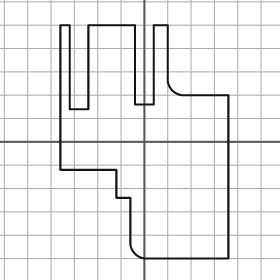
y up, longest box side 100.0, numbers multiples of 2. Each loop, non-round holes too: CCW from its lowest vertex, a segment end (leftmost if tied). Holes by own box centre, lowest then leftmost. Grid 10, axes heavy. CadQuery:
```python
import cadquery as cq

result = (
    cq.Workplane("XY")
    .moveTo(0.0, -50.0)
    .lineTo(36.0, -50.0)
    .lineTo(36.0, 20.0)
    .lineTo(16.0, 20.0)
    .threePointArc((12.0, 22.0), (10.0, 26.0))
    .lineTo(10.0, 50.0)
    .lineTo(4.0, 50.0)
    .lineTo(4.0, 16.0)
    .lineTo(-4.0, 16.0)
    .lineTo(-4.0, 50.0)
    .lineTo(-24.0, 50.0)
    .lineTo(-24.0, 14.0)
    .lineTo(-32.0, 14.0)
    .lineTo(-32.0, 50.0)
    .lineTo(-36.0, 50.0)
    .lineTo(-36.0, -12.0)
    .lineTo(-12.0, -12.0)
    .lineTo(-12.0, -24.0)
    .lineTo(-6.0, -24.0)
    .lineTo(-6.0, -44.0)
    .threePointArc((-4.0, -48.0), (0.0, -50.0))
    .close()
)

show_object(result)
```